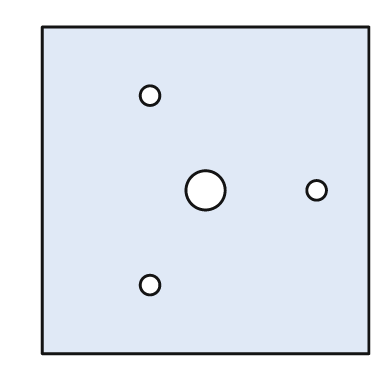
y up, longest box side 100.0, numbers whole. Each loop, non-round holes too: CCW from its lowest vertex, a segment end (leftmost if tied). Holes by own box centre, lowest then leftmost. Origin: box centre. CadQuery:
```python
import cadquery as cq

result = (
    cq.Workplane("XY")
    .moveTo(-50.0, -50.0)
    .lineTo(50.0, -50.0)
    .lineTo(50.0, 50.0)
    .lineTo(-50.0, 50.0)
    .close()
    .moveTo(-17.0, -29.0)
    .circle(3.0)
    .moveTo(0.0, 0.0)
    .circle(6.0)
    .moveTo(34.0, 0.0)
    .circle(3.0)
    .moveTo(-17.0, 29.0)
    .circle(3.0)
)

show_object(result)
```